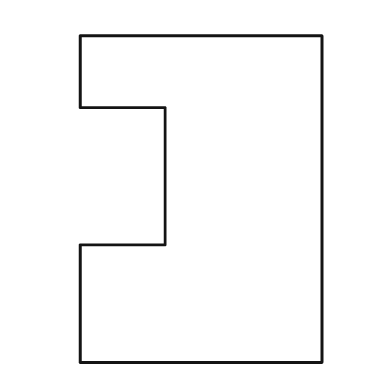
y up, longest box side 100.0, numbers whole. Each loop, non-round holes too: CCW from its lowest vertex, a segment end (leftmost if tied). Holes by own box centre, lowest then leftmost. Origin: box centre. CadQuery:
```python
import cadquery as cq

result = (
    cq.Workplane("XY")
    .moveTo(-37.0, -50.0)
    .lineTo(37.0, -50.0)
    .lineTo(37.0, 50.0)
    .lineTo(-37.0, 50.0)
    .lineTo(-37.0, 28.0)
    .lineTo(-11.0, 28.0)
    .lineTo(-11.0, -14.0)
    .lineTo(-37.0, -14.0)
    .close()
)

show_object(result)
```